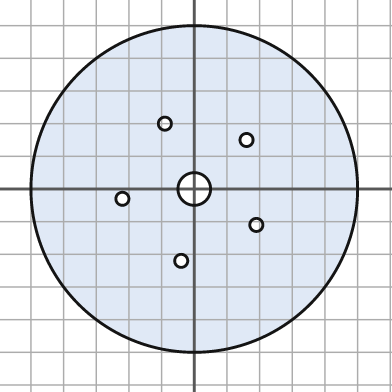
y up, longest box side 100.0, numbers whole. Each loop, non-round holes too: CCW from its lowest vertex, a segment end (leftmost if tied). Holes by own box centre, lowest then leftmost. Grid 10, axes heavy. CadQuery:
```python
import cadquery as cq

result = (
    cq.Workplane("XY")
    .moveTo(0.0, 0.0)
    .circle(50.0)
    .moveTo(-4.0, -22.0)
    .circle(2.0)
    .moveTo(19.0, -11.0)
    .circle(2.0)
    .moveTo(-22.0, -3.0)
    .circle(2.0)
    .moveTo(0.0, 0.0)
    .circle(5.0)
    .moveTo(16.0, 15.0)
    .circle(2.0)
    .moveTo(-9.0, 20.0)
    .circle(2.0)
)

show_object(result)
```